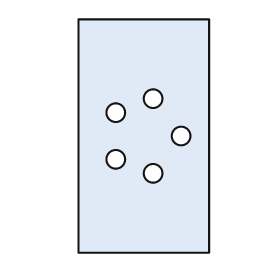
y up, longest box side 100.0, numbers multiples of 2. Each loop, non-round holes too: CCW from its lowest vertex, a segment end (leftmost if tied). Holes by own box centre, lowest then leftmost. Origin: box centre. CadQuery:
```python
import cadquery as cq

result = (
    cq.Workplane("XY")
    .moveTo(-28.0, -50.0)
    .lineTo(28.0, -50.0)
    .lineTo(28.0, 50.0)
    .lineTo(-28.0, 50.0)
    .close()
    .moveTo(4.0, -16.0)
    .circle(4.0)
    .moveTo(-12.0, -10.0)
    .circle(4.0)
    .moveTo(16.0, 0.0)
    .circle(4.0)
    .moveTo(-12.0, 10.0)
    .circle(4.0)
    .moveTo(4.0, 16.0)
    .circle(4.0)
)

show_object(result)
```